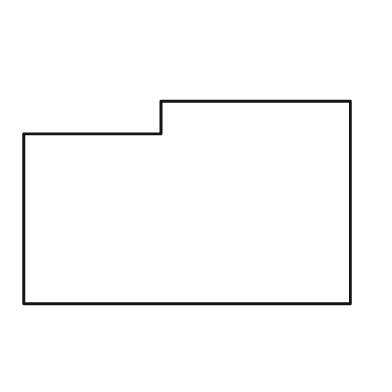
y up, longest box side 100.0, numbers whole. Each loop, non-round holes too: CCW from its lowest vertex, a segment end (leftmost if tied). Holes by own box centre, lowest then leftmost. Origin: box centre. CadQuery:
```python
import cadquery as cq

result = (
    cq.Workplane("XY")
    .moveTo(-50.0, -31.0)
    .lineTo(50.0, -31.0)
    .lineTo(50.0, 31.0)
    .lineTo(-8.0, 31.0)
    .lineTo(-8.0, 21.0)
    .lineTo(-50.0, 21.0)
    .close()
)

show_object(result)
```